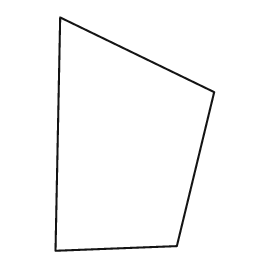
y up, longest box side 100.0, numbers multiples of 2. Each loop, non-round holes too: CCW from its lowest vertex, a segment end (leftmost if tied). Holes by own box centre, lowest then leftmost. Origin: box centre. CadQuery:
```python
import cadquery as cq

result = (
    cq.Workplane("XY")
    .moveTo(-34.0, -50.0)
    .lineTo(18.0, -48.0)
    .lineTo(34.0, 18.0)
    .lineTo(-32.0, 50.0)
    .close()
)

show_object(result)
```